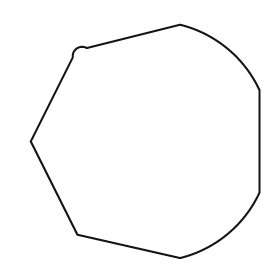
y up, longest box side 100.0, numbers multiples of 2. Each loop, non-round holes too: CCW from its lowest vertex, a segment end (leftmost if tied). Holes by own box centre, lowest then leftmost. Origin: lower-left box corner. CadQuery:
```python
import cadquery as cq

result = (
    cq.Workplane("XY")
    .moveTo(64.0, 0.0)
    .threePointArc((84.0, 10.0), (98.0, 28.0))
    .lineTo(98.0, 72.0)
    .threePointArc((84.0, 90.0), (64.0, 100.0))
    .lineTo(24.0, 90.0)
    .threePointArc((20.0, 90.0), (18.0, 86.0))
    .lineTo(0.0, 50.0)
    .lineTo(20.0, 10.0)
    .close()
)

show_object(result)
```